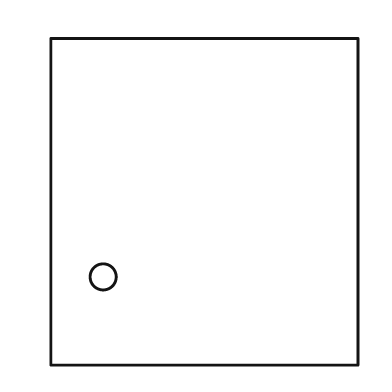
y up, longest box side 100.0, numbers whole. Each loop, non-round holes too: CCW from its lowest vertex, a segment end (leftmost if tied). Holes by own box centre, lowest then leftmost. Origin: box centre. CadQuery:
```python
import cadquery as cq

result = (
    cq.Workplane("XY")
    .moveTo(-47.0, -50.0)
    .lineTo(47.0, -50.0)
    .lineTo(47.0, 50.0)
    .lineTo(-47.0, 50.0)
    .close()
    .moveTo(-31.0, -23.0)
    .circle(4.0)
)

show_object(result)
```